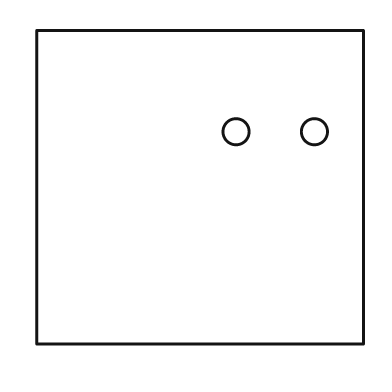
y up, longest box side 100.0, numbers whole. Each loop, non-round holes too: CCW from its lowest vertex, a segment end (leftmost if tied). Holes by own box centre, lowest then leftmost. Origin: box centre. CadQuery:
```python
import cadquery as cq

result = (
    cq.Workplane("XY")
    .moveTo(-50.0, -48.0)
    .lineTo(50.0, -48.0)
    .lineTo(50.0, 48.0)
    .lineTo(-50.0, 48.0)
    .close()
    .moveTo(11.0, 17.0)
    .circle(4.0)
    .moveTo(35.0, 17.0)
    .circle(4.0)
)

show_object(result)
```